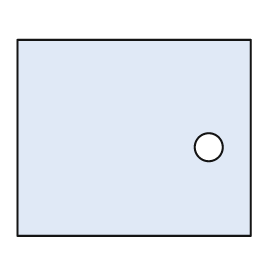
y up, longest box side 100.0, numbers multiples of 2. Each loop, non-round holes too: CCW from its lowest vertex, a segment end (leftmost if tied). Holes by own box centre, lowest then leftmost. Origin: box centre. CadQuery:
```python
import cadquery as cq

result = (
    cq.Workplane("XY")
    .moveTo(-50.0, -42.0)
    .lineTo(50.0, -42.0)
    .lineTo(50.0, 42.0)
    .lineTo(-50.0, 42.0)
    .close()
    .moveTo(32.0, -4.0)
    .circle(6.0)
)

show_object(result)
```